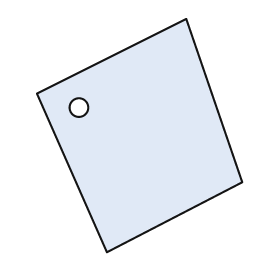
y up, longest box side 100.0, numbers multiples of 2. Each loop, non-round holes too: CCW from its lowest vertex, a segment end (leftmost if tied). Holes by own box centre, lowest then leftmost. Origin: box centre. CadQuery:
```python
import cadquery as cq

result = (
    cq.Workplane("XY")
    .moveTo(-14.0, -50.0)
    .lineTo(44.0, -20.0)
    .lineTo(20.0, 50.0)
    .lineTo(-44.0, 18.0)
    .close()
    .moveTo(-26.0, 12.0)
    .circle(4.0)
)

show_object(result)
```